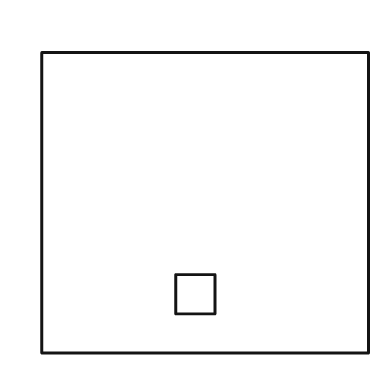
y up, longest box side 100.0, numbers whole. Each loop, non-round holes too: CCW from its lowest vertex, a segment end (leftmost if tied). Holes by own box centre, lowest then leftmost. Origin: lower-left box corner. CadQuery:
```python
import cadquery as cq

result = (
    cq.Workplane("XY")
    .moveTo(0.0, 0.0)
    .lineTo(100.0, 0.0)
    .lineTo(100.0, 92.0)
    .lineTo(0.0, 92.0)
    .close()
    .moveTo(41.0, 12.0)
    .lineTo(53.0, 12.0)
    .lineTo(53.0, 24.0)
    .lineTo(41.0, 24.0)
    .close()
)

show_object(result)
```